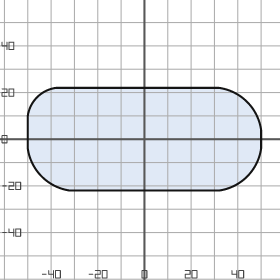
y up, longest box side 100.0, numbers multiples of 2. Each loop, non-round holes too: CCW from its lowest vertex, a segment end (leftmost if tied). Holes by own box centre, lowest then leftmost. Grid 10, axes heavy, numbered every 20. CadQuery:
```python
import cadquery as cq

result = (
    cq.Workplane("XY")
    .moveTo(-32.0, -22.0)
    .lineTo(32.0, -22.0)
    .threePointArc((44.0, -16.0), (50.0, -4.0))
    .lineTo(50.0, 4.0)
    .threePointArc((44.0, 16.0), (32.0, 22.0))
    .lineTo(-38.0, 22.0)
    .threePointArc((-46.0, 18.0), (-50.0, 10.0))
    .lineTo(-50.0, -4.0)
    .threePointArc((-44.0, -16.0), (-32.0, -22.0))
    .close()
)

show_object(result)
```